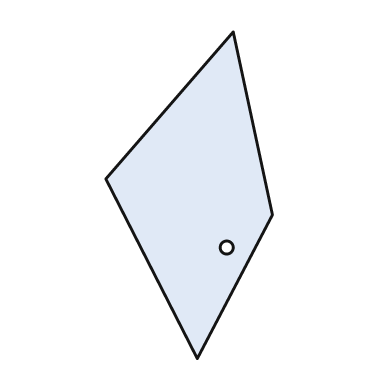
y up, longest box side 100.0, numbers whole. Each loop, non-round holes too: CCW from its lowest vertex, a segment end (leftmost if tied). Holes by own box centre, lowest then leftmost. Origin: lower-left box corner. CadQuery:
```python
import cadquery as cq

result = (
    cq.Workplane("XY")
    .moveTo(28.0, 0.0)
    .lineTo(51.0, 44.0)
    .lineTo(39.0, 100.0)
    .lineTo(0.0, 55.0)
    .close()
    .moveTo(37.0, 34.0)
    .circle(2.0)
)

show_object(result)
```